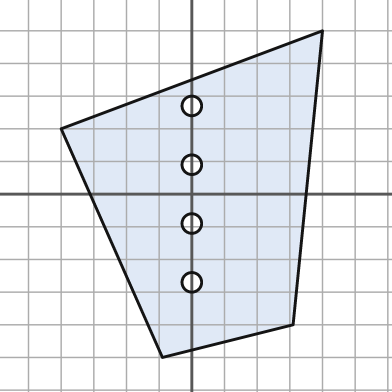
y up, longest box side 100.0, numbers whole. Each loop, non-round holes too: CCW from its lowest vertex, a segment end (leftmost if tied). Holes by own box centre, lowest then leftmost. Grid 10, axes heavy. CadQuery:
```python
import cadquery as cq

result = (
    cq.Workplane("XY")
    .moveTo(-9.0, -50.0)
    .lineTo(31.0, -40.0)
    .lineTo(40.0, 50.0)
    .lineTo(-40.0, 20.0)
    .close()
    .moveTo(0.0, -27.0)
    .circle(3.0)
    .moveTo(0.0, -9.0)
    .circle(3.0)
    .moveTo(0.0, 9.0)
    .circle(3.0)
    .moveTo(0.0, 27.0)
    .circle(3.0)
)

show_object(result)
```